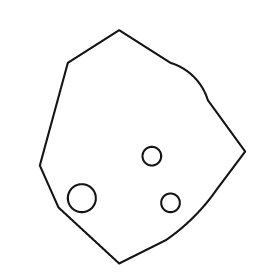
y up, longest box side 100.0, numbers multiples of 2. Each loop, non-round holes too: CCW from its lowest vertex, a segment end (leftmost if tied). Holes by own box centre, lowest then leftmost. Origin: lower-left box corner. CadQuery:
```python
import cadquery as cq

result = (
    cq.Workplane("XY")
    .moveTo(34.0, 0.0)
    .lineTo(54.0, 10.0)
    .threePointArc((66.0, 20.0), (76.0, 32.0))
    .lineTo(88.0, 48.0)
    .lineTo(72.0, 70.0)
    .threePointArc((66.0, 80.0), (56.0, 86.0))
    .lineTo(34.0, 100.0)
    .lineTo(12.0, 86.0)
    .lineTo(0.0, 42.0)
    .lineTo(8.0, 24.0)
    .close()
    .moveTo(56.0, 26.0)
    .circle(4.0)
    .moveTo(18.0, 28.0)
    .circle(6.0)
    .moveTo(48.0, 46.0)
    .circle(4.0)
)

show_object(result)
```